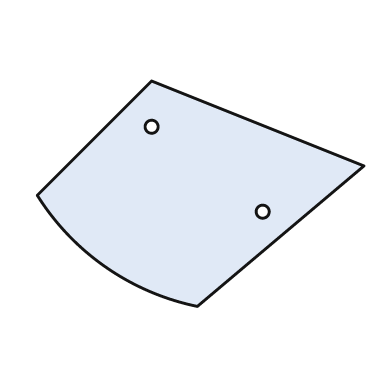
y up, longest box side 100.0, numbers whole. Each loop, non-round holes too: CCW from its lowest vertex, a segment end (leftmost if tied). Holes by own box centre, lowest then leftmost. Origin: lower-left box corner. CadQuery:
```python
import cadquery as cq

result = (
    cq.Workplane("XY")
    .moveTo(49.0, 0.0)
    .lineTo(100.0, 43.0)
    .lineTo(35.0, 69.0)
    .lineTo(0.0, 34.0)
    .threePointArc((21.0, 12.0), (49.0, 0.0))
    .close()
    .moveTo(69.0, 29.0)
    .circle(2.0)
    .moveTo(35.0, 55.0)
    .circle(2.0)
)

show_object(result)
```